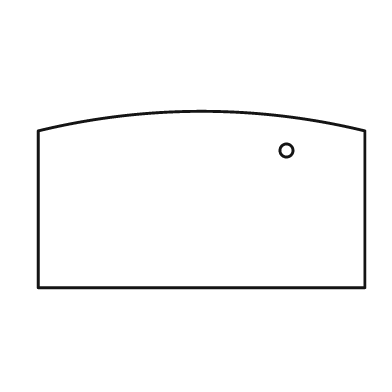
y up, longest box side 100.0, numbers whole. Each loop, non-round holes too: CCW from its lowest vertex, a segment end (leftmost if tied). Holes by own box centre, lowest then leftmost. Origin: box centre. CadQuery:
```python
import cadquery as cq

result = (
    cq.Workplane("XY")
    .moveTo(-50.0, -27.0)
    .lineTo(50.0, -27.0)
    .lineTo(50.0, 21.0)
    .threePointArc((0.0, 27.0), (-50.0, 21.0))
    .close()
    .moveTo(26.0, 15.0)
    .circle(2.0)
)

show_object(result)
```